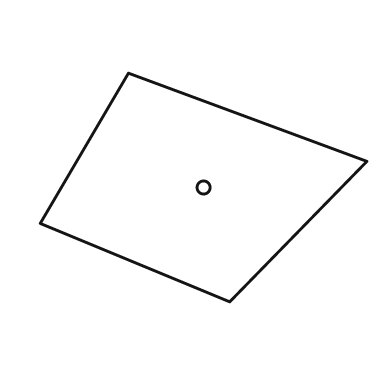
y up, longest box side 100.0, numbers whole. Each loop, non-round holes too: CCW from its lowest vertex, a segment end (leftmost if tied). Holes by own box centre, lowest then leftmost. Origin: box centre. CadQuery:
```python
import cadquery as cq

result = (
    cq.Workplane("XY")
    .moveTo(8.0, -35.0)
    .lineTo(50.0, 8.0)
    .lineTo(-23.0, 35.0)
    .lineTo(-50.0, -11.0)
    .close()
    .moveTo(0.0, 0.0)
    .circle(2.0)
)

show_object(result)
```